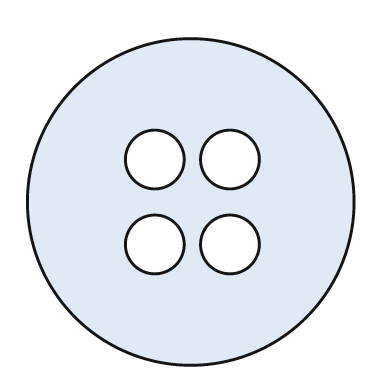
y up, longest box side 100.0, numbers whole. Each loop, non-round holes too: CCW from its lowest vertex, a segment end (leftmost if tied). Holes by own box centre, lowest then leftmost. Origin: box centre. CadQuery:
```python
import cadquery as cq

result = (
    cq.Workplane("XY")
    .moveTo(0.0, 0.0)
    .circle(50.0)
    .moveTo(-11.0, -13.0)
    .circle(9.0)
    .moveTo(12.0, -13.0)
    .circle(9.0)
    .moveTo(-11.0, 13.0)
    .circle(9.0)
    .moveTo(12.0, 13.0)
    .circle(9.0)
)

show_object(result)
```